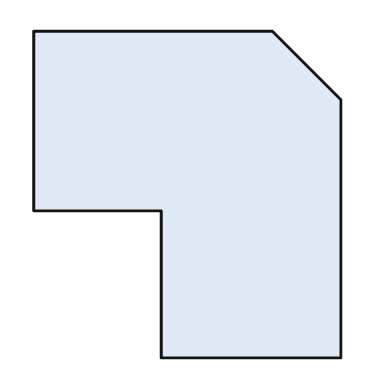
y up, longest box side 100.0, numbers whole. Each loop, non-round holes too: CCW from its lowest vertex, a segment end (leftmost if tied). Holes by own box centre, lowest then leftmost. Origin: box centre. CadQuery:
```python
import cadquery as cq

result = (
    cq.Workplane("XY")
    .moveTo(-8.0, -50.0)
    .lineTo(47.0, -50.0)
    .lineTo(47.0, 29.0)
    .lineTo(26.0, 50.0)
    .lineTo(-47.0, 50.0)
    .lineTo(-47.0, -5.0)
    .lineTo(-8.0, -5.0)
    .close()
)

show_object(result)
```